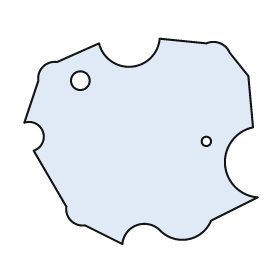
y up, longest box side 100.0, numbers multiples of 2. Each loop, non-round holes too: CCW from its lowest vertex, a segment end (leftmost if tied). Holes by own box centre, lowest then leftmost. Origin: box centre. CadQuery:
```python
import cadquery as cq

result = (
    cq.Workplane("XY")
    .moveTo(-8.0, -44.0)
    .threePointArc((-2.0, -36.0), (8.0, -38.0))
    .threePointArc((20.0, -42.0), (30.0, -34.0))
    .lineTo(50.0, -24.0)
    .threePointArc((36.0, -10.0), (48.0, 6.0))
    .lineTo(46.0, 28.0)
    .lineTo(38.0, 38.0)
    .threePointArc((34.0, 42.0), (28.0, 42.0))
    .lineTo(8.0, 44.0)
    .threePointArc((-4.0, 32.0), (-18.0, 42.0))
    .lineTo(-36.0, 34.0)
    .threePointArc((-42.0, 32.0), (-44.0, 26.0))
    .lineTo(-50.0, 8.0)
    .threePointArc((-42.0, 4.0), (-46.0, -4.0))
    .lineTo(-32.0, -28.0)
    .threePointArc((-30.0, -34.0), (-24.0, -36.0))
    .close()
    .moveTo(28.0, 0.0)
    .circle(2.0)
    .moveTo(-26.0, 26.0)
    .circle(4.0)
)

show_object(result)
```